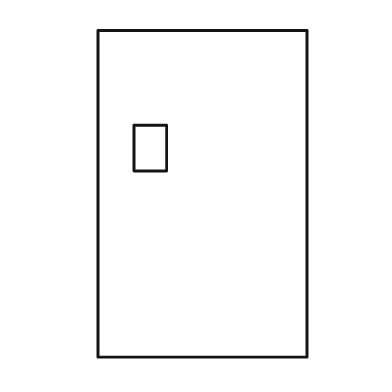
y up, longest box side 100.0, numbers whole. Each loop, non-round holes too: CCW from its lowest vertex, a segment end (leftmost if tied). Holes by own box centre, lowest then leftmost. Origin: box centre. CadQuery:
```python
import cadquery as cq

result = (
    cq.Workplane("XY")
    .moveTo(-32.0, -50.0)
    .lineTo(32.0, -50.0)
    .lineTo(32.0, 50.0)
    .lineTo(-32.0, 50.0)
    .close()
    .moveTo(-21.0, 7.0)
    .lineTo(-11.0, 7.0)
    .lineTo(-11.0, 21.0)
    .lineTo(-21.0, 21.0)
    .close()
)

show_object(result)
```